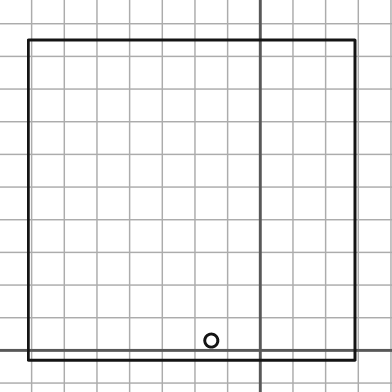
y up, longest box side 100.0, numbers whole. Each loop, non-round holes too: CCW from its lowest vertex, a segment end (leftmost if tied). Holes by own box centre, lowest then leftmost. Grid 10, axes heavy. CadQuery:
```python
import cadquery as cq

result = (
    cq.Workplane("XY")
    .moveTo(-71.0, -3.0)
    .lineTo(29.0, -3.0)
    .lineTo(29.0, 95.0)
    .lineTo(-71.0, 95.0)
    .close()
    .moveTo(-15.0, 3.0)
    .circle(2.0)
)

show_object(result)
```